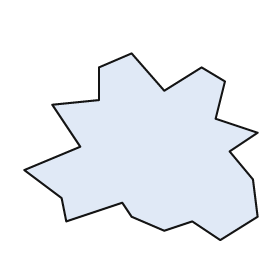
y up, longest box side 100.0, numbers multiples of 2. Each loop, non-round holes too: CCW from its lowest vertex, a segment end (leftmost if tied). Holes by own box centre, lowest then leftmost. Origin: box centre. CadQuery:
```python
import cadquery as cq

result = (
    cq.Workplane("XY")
    .moveTo(34.0, -40.0)
    .lineTo(50.0, -30.0)
    .lineTo(48.0, -14.0)
    .lineTo(38.0, -2.0)
    .lineTo(50.0, 6.0)
    .lineTo(32.0, 12.0)
    .lineTo(36.0, 28.0)
    .lineTo(26.0, 34.0)
    .lineTo(10.0, 24.0)
    .lineTo(-4.0, 40.0)
    .lineTo(-18.0, 34.0)
    .lineTo(-18.0, 20.0)
    .lineTo(-38.0, 18.0)
    .lineTo(-26.0, 0.0)
    .lineTo(-50.0, -10.0)
    .lineTo(-34.0, -22.0)
    .lineTo(-32.0, -32.0)
    .lineTo(-8.0, -24.0)
    .lineTo(-4.0, -30.0)
    .lineTo(10.0, -36.0)
    .lineTo(22.0, -32.0)
    .close()
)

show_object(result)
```